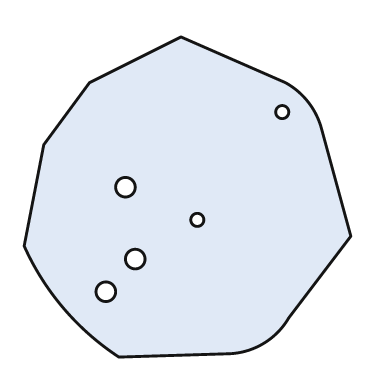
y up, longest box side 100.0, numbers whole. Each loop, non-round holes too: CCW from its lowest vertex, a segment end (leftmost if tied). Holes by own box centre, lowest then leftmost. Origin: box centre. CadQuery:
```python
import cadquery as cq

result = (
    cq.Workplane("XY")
    .moveTo(-21.0, -49.0)
    .lineTo(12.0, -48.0)
    .threePointArc((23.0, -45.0), (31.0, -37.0))
    .lineTo(50.0, -12.0)
    .lineTo(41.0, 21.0)
    .threePointArc((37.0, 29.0), (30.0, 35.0))
    .lineTo(-2.0, 49.0)
    .lineTo(-30.0, 35.0)
    .lineTo(-44.0, 16.0)
    .lineTo(-50.0, -15.0)
    .threePointArc((-38.0, -34.0), (-21.0, -49.0))
    .close()
    .moveTo(-25.0, -29.0)
    .circle(3.0)
    .moveTo(-16.0, -19.0)
    .circle(3.0)
    .moveTo(3.0, -7.0)
    .circle(2.0)
    .moveTo(-19.0, 3.0)
    .circle(3.0)
    .moveTo(29.0, 26.0)
    .circle(2.0)
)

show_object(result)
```